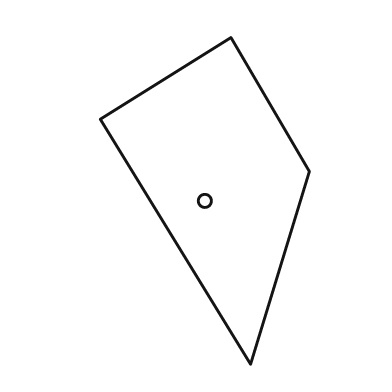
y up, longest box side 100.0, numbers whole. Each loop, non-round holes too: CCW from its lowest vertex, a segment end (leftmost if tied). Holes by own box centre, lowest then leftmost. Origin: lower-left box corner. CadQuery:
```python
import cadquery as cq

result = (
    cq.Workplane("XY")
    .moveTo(46.0, 0.0)
    .lineTo(64.0, 59.0)
    .lineTo(40.0, 100.0)
    .lineTo(0.0, 75.0)
    .close()
    .moveTo(32.0, 50.0)
    .circle(2.0)
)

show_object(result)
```